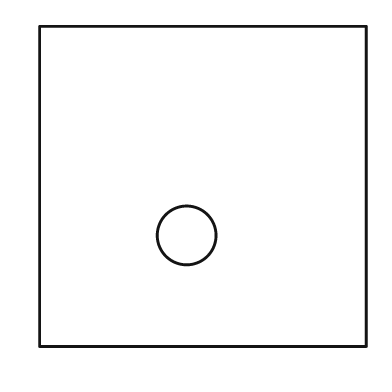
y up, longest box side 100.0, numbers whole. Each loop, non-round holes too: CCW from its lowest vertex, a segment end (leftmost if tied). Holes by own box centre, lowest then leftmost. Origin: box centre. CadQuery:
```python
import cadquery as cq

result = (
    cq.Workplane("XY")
    .moveTo(-50.0, -49.0)
    .lineTo(50.0, -49.0)
    .lineTo(50.0, 49.0)
    .lineTo(-50.0, 49.0)
    .close()
    .moveTo(-5.0, -15.0)
    .circle(9.0)
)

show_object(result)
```